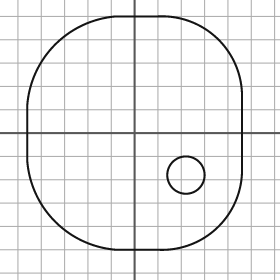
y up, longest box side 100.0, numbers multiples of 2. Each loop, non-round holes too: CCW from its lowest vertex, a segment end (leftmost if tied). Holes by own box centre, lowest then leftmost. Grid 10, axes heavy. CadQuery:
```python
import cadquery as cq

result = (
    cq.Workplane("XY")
    .moveTo(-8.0, -50.0)
    .lineTo(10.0, -50.0)
    .threePointArc((36.0, -40.0), (46.0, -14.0))
    .lineTo(46.0, 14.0)
    .threePointArc((36.0, 40.0), (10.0, 50.0))
    .lineTo(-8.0, 50.0)
    .threePointArc((-34.0, 38.0), (-46.0, 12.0))
    .lineTo(-46.0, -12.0)
    .threePointArc((-34.0, -38.0), (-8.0, -50.0))
    .close()
    .moveTo(22.0, -18.0)
    .circle(8.0)
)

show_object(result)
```